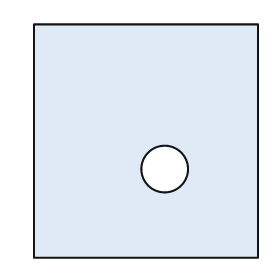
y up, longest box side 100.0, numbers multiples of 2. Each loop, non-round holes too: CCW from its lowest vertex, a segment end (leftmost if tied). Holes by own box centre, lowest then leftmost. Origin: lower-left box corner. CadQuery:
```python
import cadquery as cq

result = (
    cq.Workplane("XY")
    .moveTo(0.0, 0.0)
    .lineTo(96.0, 0.0)
    .lineTo(96.0, 100.0)
    .lineTo(0.0, 100.0)
    .close()
    .moveTo(56.0, 38.0)
    .circle(10.0)
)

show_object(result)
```